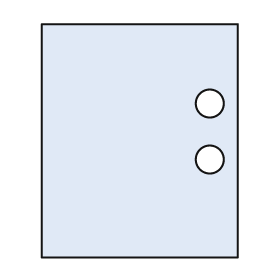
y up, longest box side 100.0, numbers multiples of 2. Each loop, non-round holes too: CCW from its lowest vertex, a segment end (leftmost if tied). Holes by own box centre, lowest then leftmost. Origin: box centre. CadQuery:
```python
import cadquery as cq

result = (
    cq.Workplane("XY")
    .moveTo(-42.0, -50.0)
    .lineTo(42.0, -50.0)
    .lineTo(42.0, 50.0)
    .lineTo(-42.0, 50.0)
    .close()
    .moveTo(30.0, -8.0)
    .circle(6.0)
    .moveTo(30.0, 16.0)
    .circle(6.0)
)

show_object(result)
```